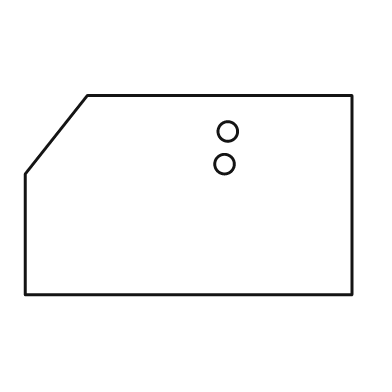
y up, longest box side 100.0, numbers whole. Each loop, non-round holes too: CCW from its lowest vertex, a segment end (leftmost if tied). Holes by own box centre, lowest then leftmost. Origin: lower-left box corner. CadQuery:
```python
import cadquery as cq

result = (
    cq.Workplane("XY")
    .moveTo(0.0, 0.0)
    .lineTo(100.0, 0.0)
    .lineTo(100.0, 61.0)
    .lineTo(19.0, 61.0)
    .lineTo(0.0, 37.0)
    .close()
    .moveTo(61.0, 40.0)
    .circle(3.0)
    .moveTo(62.0, 50.0)
    .circle(3.0)
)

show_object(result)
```